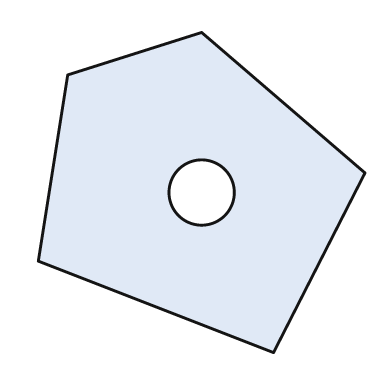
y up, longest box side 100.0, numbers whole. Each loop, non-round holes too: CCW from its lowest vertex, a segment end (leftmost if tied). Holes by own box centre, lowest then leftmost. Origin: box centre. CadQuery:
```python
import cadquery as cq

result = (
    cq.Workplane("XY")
    .moveTo(22.0, -49.0)
    .lineTo(50.0, 6.0)
    .lineTo(0.0, 49.0)
    .lineTo(-41.0, 36.0)
    .lineTo(-50.0, -21.0)
    .close()
    .moveTo(0.0, 0.0)
    .circle(10.0)
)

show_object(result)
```